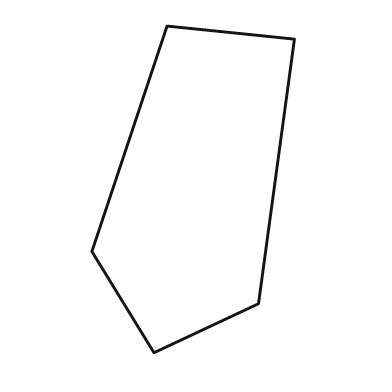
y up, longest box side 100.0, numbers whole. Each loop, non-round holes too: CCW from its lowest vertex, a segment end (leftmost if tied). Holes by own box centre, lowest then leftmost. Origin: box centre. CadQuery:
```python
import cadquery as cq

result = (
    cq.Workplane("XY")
    .moveTo(-12.0, -50.0)
    .lineTo(20.0, -35.0)
    .lineTo(31.0, 46.0)
    .lineTo(-8.0, 50.0)
    .lineTo(-31.0, -19.0)
    .close()
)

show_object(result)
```